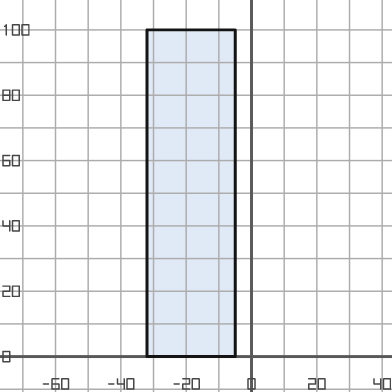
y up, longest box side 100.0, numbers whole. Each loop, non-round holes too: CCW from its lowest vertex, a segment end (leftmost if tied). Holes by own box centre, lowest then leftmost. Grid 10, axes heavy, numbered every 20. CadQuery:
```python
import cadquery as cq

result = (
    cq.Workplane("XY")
    .moveTo(-32.0, 0.0)
    .lineTo(-5.0, 0.0)
    .lineTo(-5.0, 100.0)
    .lineTo(-32.0, 100.0)
    .close()
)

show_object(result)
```